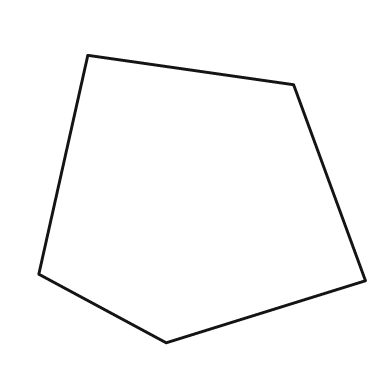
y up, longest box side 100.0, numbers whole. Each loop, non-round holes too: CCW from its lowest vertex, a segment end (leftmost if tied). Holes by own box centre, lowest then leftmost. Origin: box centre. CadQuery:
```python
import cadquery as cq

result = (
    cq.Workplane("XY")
    .moveTo(-11.0, -44.0)
    .lineTo(50.0, -25.0)
    .lineTo(28.0, 35.0)
    .lineTo(-35.0, 44.0)
    .lineTo(-50.0, -23.0)
    .close()
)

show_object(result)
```